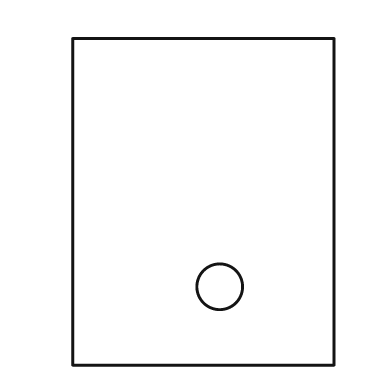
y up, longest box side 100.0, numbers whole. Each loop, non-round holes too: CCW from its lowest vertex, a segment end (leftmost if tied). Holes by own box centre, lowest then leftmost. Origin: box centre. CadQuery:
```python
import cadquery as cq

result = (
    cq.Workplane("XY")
    .moveTo(-40.0, -50.0)
    .lineTo(40.0, -50.0)
    .lineTo(40.0, 50.0)
    .lineTo(-40.0, 50.0)
    .close()
    .moveTo(5.0, -26.0)
    .circle(7.0)
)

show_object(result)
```